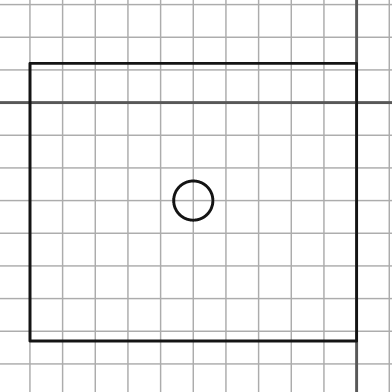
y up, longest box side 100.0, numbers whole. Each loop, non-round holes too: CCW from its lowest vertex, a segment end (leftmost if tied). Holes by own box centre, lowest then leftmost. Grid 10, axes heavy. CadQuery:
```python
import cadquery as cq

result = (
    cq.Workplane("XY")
    .moveTo(-100.0, -73.0)
    .lineTo(0.0, -73.0)
    .lineTo(0.0, 12.0)
    .lineTo(-100.0, 12.0)
    .close()
    .moveTo(-50.0, -30.0)
    .circle(6.0)
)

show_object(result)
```